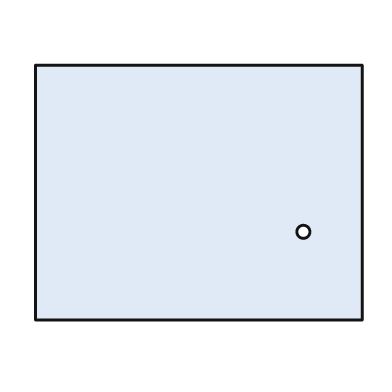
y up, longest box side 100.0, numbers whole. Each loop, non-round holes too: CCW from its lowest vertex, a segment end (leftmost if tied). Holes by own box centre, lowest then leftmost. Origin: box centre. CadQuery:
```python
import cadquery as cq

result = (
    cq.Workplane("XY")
    .moveTo(-50.0, -39.0)
    .lineTo(50.0, -39.0)
    .lineTo(50.0, 39.0)
    .lineTo(-50.0, 39.0)
    .close()
    .moveTo(32.0, -12.0)
    .circle(2.0)
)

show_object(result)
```